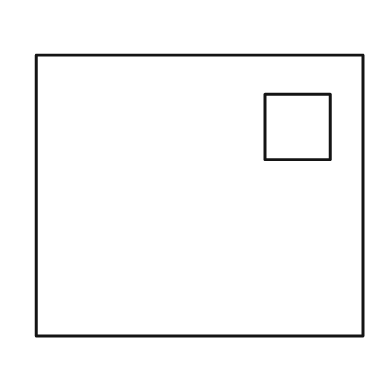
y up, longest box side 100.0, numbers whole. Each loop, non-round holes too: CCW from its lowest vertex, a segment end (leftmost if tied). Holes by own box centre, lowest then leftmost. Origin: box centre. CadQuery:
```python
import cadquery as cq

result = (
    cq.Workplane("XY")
    .moveTo(-50.0, -43.0)
    .lineTo(50.0, -43.0)
    .lineTo(50.0, 43.0)
    .lineTo(-50.0, 43.0)
    .close()
    .moveTo(20.0, 11.0)
    .lineTo(40.0, 11.0)
    .lineTo(40.0, 31.0)
    .lineTo(20.0, 31.0)
    .close()
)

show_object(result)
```